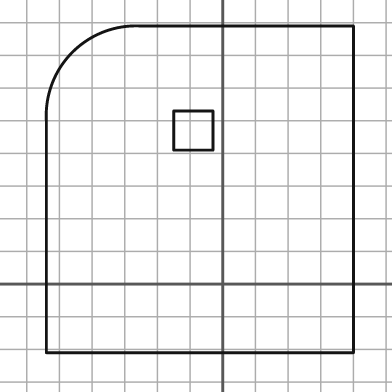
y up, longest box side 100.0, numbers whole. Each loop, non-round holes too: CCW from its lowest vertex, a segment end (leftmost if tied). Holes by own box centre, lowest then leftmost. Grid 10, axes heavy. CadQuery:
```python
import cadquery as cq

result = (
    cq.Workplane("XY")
    .moveTo(-54.0, -21.0)
    .lineTo(40.0, -21.0)
    .lineTo(40.0, 79.0)
    .lineTo(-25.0, 79.0)
    .threePointArc((-46.0, 71.0), (-54.0, 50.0))
    .close()
    .moveTo(-15.0, 41.0)
    .lineTo(-3.0, 41.0)
    .lineTo(-3.0, 53.0)
    .lineTo(-15.0, 53.0)
    .close()
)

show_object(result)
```